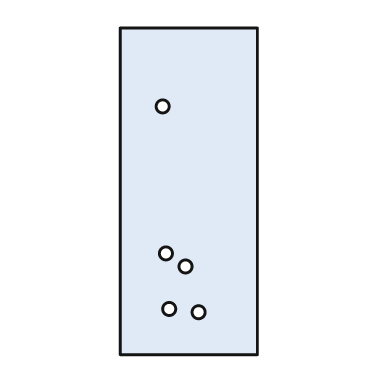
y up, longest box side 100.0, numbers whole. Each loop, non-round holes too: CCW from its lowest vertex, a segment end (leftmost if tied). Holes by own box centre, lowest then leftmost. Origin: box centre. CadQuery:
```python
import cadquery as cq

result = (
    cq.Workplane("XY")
    .moveTo(-21.0, -50.0)
    .lineTo(21.0, -50.0)
    .lineTo(21.0, 50.0)
    .lineTo(-21.0, 50.0)
    .close()
    .moveTo(3.0, -37.0)
    .circle(2.0)
    .moveTo(-6.0, -36.0)
    .circle(2.0)
    .moveTo(-1.0, -23.0)
    .circle(2.0)
    .moveTo(-7.0, -19.0)
    .circle(2.0)
    .moveTo(-8.0, 26.0)
    .circle(2.0)
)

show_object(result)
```